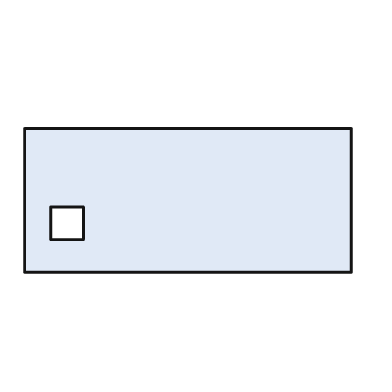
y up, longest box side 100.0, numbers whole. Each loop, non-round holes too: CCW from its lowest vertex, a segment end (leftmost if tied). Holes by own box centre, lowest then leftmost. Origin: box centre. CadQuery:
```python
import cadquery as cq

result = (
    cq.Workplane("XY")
    .moveTo(-50.0, -22.0)
    .lineTo(50.0, -22.0)
    .lineTo(50.0, 22.0)
    .lineTo(-50.0, 22.0)
    .close()
    .moveTo(-42.0, -12.0)
    .lineTo(-32.0, -12.0)
    .lineTo(-32.0, -2.0)
    .lineTo(-42.0, -2.0)
    .close()
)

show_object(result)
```